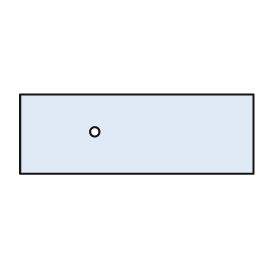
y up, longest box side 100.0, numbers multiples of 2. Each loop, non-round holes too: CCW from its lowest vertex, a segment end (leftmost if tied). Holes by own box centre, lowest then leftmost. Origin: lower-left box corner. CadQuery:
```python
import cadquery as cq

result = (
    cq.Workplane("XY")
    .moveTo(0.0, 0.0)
    .lineTo(100.0, 0.0)
    .lineTo(100.0, 34.0)
    .lineTo(0.0, 34.0)
    .close()
    .moveTo(32.0, 18.0)
    .circle(2.0)
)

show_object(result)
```